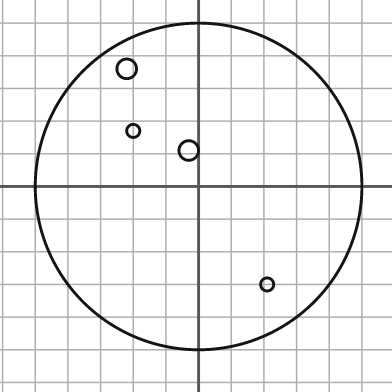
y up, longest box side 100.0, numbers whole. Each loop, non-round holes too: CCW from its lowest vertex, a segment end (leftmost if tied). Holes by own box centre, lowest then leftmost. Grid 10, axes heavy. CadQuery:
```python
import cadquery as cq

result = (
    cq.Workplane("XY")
    .moveTo(0.0, 0.0)
    .circle(50.0)
    .moveTo(21.0, -30.0)
    .circle(2.0)
    .moveTo(-3.0, 11.0)
    .circle(3.0)
    .moveTo(-20.0, 17.0)
    .circle(2.0)
    .moveTo(-22.0, 36.0)
    .circle(3.0)
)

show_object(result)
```